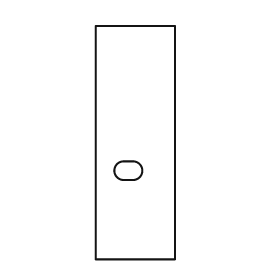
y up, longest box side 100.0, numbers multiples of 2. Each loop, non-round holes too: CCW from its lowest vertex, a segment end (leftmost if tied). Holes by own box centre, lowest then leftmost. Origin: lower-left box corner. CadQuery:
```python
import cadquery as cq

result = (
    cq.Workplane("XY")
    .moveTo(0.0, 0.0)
    .lineTo(34.0, 0.0)
    .lineTo(34.0, 100.0)
    .lineTo(0.0, 100.0)
    .close()
    .moveTo(12.0, 34.0)
    .lineTo(16.0, 34.0)
    .threePointArc((20.0, 38.0), (16.0, 42.0))
    .lineTo(12.0, 42.0)
    .threePointArc((8.0, 38.0), (12.0, 34.0))
    .close()
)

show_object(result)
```